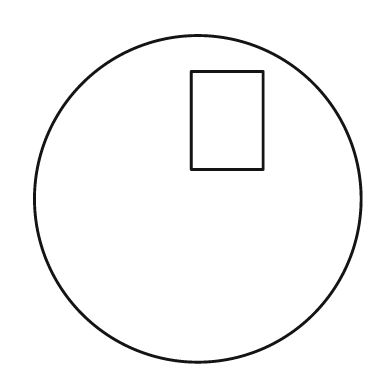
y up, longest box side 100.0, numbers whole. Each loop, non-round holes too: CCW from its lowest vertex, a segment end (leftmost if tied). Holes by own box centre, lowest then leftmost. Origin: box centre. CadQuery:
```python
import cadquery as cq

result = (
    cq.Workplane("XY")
    .moveTo(0.0, 0.0)
    .circle(50.0)
    .moveTo(-2.0, 9.0)
    .lineTo(20.0, 9.0)
    .lineTo(20.0, 39.0)
    .lineTo(-2.0, 39.0)
    .close()
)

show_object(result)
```